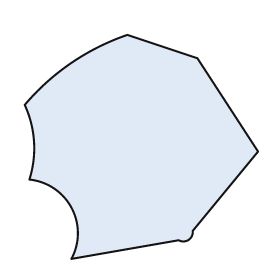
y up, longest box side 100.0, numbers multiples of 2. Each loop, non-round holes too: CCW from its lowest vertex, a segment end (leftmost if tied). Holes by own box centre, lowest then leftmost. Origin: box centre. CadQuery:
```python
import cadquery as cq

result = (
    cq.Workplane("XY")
    .moveTo(-30.0, -48.0)
    .lineTo(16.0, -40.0)
    .threePointArc((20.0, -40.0), (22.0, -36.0))
    .lineTo(50.0, -2.0)
    .lineTo(24.0, 38.0)
    .lineTo(-6.0, 48.0)
    .threePointArc((-30.0, 36.0), (-50.0, 18.0))
    .threePointArc((-46.0, 2.0), (-48.0, -14.0))
    .threePointArc((-30.0, -26.0), (-30.0, -48.0))
    .close()
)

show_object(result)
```